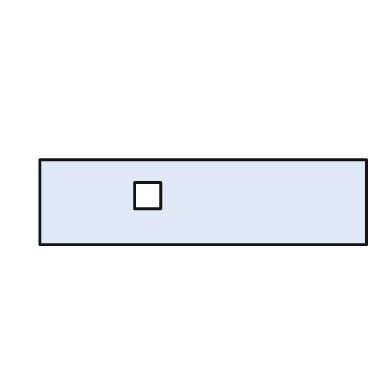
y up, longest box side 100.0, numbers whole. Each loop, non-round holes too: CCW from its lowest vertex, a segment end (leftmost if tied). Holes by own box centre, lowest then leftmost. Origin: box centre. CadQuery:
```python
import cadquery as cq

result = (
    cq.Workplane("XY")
    .moveTo(-50.0, -13.0)
    .lineTo(50.0, -13.0)
    .lineTo(50.0, 13.0)
    .lineTo(-50.0, 13.0)
    .close()
    .moveTo(-21.0, -2.0)
    .lineTo(-13.0, -2.0)
    .lineTo(-13.0, 6.0)
    .lineTo(-21.0, 6.0)
    .close()
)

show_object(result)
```